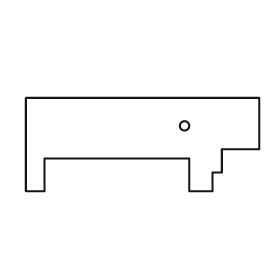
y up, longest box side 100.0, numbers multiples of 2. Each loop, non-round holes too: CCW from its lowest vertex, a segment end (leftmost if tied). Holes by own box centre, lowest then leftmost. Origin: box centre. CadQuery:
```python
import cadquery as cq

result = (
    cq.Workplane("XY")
    .moveTo(-50.0, -20.0)
    .lineTo(-42.0, -20.0)
    .lineTo(-42.0, -6.0)
    .lineTo(20.0, -6.0)
    .lineTo(20.0, -20.0)
    .lineTo(30.0, -20.0)
    .lineTo(30.0, -12.0)
    .lineTo(34.0, -12.0)
    .lineTo(34.0, -2.0)
    .lineTo(50.0, -2.0)
    .lineTo(50.0, 20.0)
    .lineTo(-50.0, 20.0)
    .close()
    .moveTo(18.0, 8.0)
    .circle(2.0)
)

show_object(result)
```